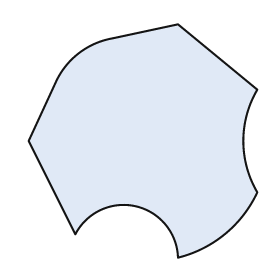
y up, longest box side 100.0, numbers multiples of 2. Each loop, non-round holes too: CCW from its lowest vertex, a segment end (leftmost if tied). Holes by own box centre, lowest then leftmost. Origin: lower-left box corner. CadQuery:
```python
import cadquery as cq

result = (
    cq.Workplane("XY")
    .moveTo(64.0, 0.0)
    .threePointArc((84.0, 10.0), (98.0, 28.0))
    .threePointArc((92.0, 50.0), (98.0, 72.0))
    .lineTo(64.0, 100.0)
    .lineTo(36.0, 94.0)
    .threePointArc((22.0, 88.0), (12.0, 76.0))
    .lineTo(0.0, 50.0)
    .lineTo(20.0, 10.0)
    .threePointArc((46.0, 22.0), (64.0, 0.0))
    .close()
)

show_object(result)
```